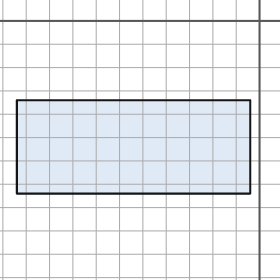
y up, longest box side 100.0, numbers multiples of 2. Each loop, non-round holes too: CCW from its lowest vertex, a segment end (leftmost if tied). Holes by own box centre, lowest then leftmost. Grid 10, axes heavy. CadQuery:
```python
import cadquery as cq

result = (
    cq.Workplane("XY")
    .moveTo(-104.0, -74.0)
    .lineTo(-4.0, -74.0)
    .lineTo(-4.0, -34.0)
    .lineTo(-104.0, -34.0)
    .close()
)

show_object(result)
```